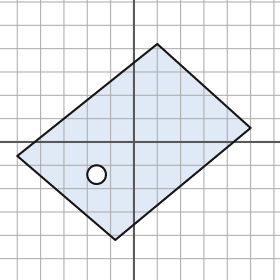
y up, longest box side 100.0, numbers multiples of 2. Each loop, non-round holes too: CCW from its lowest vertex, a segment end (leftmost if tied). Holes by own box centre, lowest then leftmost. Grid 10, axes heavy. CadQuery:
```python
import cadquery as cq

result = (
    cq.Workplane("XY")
    .moveTo(-8.0, -42.0)
    .lineTo(50.0, 6.0)
    .lineTo(10.0, 42.0)
    .lineTo(-50.0, -6.0)
    .close()
    .moveTo(-16.0, -14.0)
    .circle(4.0)
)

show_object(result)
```